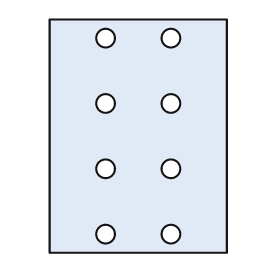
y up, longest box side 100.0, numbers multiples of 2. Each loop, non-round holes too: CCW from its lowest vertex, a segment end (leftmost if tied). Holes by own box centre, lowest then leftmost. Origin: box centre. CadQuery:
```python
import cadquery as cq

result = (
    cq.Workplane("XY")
    .moveTo(-38.0, -50.0)
    .lineTo(38.0, -50.0)
    .lineTo(38.0, 50.0)
    .lineTo(-38.0, 50.0)
    .close()
    .moveTo(-14.0, -42.0)
    .circle(4.0)
    .moveTo(14.0, -42.0)
    .circle(4.0)
    .moveTo(-14.0, -14.0)
    .circle(4.0)
    .moveTo(14.0, -14.0)
    .circle(4.0)
    .moveTo(-14.0, 14.0)
    .circle(4.0)
    .moveTo(14.0, 14.0)
    .circle(4.0)
    .moveTo(-14.0, 42.0)
    .circle(4.0)
    .moveTo(14.0, 42.0)
    .circle(4.0)
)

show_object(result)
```